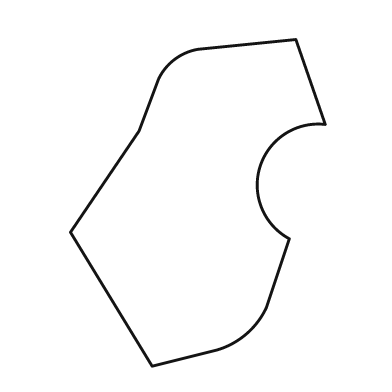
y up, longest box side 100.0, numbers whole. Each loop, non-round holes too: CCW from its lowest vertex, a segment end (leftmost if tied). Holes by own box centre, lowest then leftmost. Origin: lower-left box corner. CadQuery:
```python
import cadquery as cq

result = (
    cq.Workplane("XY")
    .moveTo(25.0, 0.0)
    .lineTo(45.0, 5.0)
    .threePointArc((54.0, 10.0), (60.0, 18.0))
    .lineTo(67.0, 39.0)
    .threePointArc((58.0, 61.0), (78.0, 74.0))
    .lineTo(69.0, 100.0)
    .lineTo(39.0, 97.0)
    .threePointArc((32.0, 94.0), (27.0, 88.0))
    .lineTo(21.0, 72.0)
    .lineTo(0.0, 41.0)
    .close()
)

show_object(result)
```